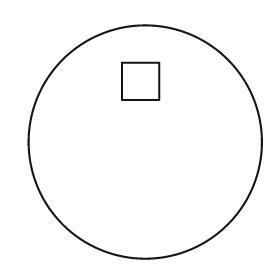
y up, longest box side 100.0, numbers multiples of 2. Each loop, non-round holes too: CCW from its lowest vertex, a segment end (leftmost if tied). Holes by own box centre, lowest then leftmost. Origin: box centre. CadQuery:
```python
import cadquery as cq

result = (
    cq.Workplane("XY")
    .moveTo(0.0, 0.0)
    .circle(50.0)
    .moveTo(-10.0, 18.0)
    .lineTo(6.0, 18.0)
    .lineTo(6.0, 34.0)
    .lineTo(-10.0, 34.0)
    .close()
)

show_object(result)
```